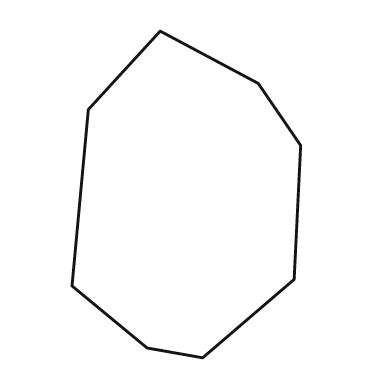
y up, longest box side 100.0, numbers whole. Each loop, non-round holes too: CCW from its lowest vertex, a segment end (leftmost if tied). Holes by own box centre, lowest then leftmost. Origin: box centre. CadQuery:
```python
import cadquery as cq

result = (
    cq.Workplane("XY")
    .moveTo(5.0, -50.0)
    .lineTo(33.0, -26.0)
    .lineTo(35.0, 15.0)
    .lineTo(22.0, 34.0)
    .lineTo(-8.0, 50.0)
    .lineTo(-30.0, 26.0)
    .lineTo(-35.0, -28.0)
    .lineTo(-12.0, -47.0)
    .close()
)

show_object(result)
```